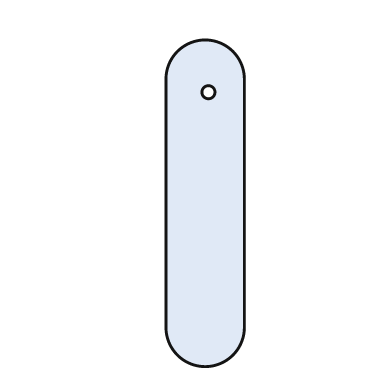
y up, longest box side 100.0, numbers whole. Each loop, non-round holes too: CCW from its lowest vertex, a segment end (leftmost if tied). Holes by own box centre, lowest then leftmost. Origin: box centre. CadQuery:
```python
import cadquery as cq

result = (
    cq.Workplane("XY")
    .moveTo(-12.0, -38.0)
    .threePointArc((0.0, -50.0), (12.0, -38.0))
    .lineTo(12.0, 38.0)
    .threePointArc((0.0, 50.0), (-12.0, 38.0))
    .close()
    .moveTo(1.0, 34.0)
    .circle(2.0)
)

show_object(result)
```